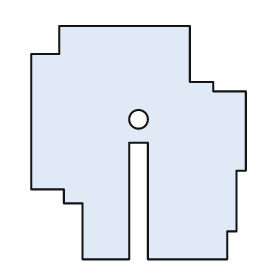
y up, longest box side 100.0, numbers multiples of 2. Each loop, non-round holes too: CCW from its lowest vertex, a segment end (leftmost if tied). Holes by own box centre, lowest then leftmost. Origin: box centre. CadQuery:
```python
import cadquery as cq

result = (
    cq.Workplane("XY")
    .moveTo(-24.0, -50.0)
    .lineTo(-4.0, -50.0)
    .lineTo(-4.0, 0.0)
    .lineTo(4.0, 0.0)
    .lineTo(4.0, -50.0)
    .lineTo(38.0, -50.0)
    .lineTo(38.0, -38.0)
    .lineTo(42.0, -38.0)
    .lineTo(42.0, -12.0)
    .lineTo(46.0, -12.0)
    .lineTo(46.0, 22.0)
    .lineTo(32.0, 22.0)
    .lineTo(32.0, 26.0)
    .lineTo(22.0, 26.0)
    .lineTo(22.0, 50.0)
    .lineTo(-34.0, 50.0)
    .lineTo(-34.0, 38.0)
    .lineTo(-46.0, 38.0)
    .lineTo(-46.0, -20.0)
    .lineTo(-32.0, -20.0)
    .lineTo(-32.0, -26.0)
    .lineTo(-24.0, -26.0)
    .close()
    .moveTo(0.0, 10.0)
    .circle(4.0)
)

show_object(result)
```